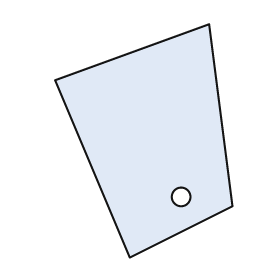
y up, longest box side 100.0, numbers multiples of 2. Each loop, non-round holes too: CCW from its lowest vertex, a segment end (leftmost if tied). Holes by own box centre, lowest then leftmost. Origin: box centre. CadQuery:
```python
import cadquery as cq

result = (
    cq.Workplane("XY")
    .moveTo(-6.0, -50.0)
    .lineTo(38.0, -28.0)
    .lineTo(28.0, 50.0)
    .lineTo(-38.0, 26.0)
    .close()
    .moveTo(16.0, -24.0)
    .circle(4.0)
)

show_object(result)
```